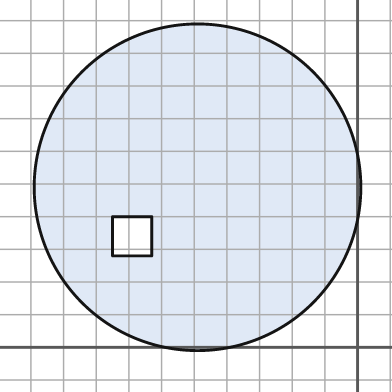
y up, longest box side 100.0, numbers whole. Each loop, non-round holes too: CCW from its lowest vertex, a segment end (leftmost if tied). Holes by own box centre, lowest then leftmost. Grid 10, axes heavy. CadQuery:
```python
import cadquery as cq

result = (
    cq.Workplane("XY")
    .moveTo(-49.0, 49.0)
    .circle(50.0)
    .moveTo(-75.0, 28.0)
    .lineTo(-63.0, 28.0)
    .lineTo(-63.0, 40.0)
    .lineTo(-75.0, 40.0)
    .close()
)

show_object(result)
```